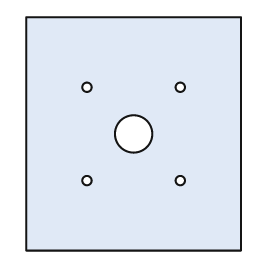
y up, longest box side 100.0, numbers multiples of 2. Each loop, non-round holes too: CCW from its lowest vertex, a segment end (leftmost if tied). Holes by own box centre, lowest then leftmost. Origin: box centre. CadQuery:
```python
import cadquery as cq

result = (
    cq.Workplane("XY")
    .moveTo(-46.0, -50.0)
    .lineTo(46.0, -50.0)
    .lineTo(46.0, 50.0)
    .lineTo(-46.0, 50.0)
    .close()
    .moveTo(-20.0, -20.0)
    .circle(2.0)
    .moveTo(20.0, -20.0)
    .circle(2.0)
    .moveTo(0.0, 0.0)
    .circle(8.0)
    .moveTo(-20.0, 20.0)
    .circle(2.0)
    .moveTo(20.0, 20.0)
    .circle(2.0)
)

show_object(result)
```